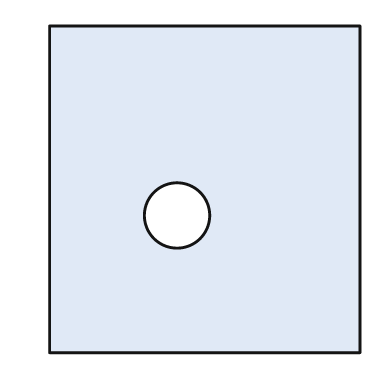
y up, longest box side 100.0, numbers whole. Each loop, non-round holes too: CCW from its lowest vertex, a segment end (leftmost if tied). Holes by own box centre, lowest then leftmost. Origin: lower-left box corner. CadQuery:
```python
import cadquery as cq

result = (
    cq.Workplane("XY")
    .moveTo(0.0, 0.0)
    .lineTo(95.0, 0.0)
    .lineTo(95.0, 100.0)
    .lineTo(0.0, 100.0)
    .close()
    .moveTo(39.0, 42.0)
    .circle(10.0)
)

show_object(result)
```